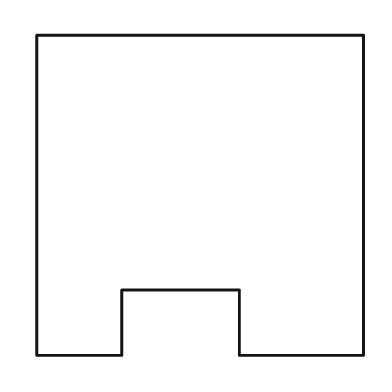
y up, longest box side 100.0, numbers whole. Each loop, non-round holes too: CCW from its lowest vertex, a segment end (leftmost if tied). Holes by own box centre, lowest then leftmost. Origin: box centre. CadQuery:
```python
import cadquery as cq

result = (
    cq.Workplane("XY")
    .moveTo(-50.0, -49.0)
    .lineTo(-24.0, -49.0)
    .lineTo(-24.0, -29.0)
    .lineTo(12.0, -29.0)
    .lineTo(12.0, -49.0)
    .lineTo(50.0, -49.0)
    .lineTo(50.0, 49.0)
    .lineTo(-50.0, 49.0)
    .close()
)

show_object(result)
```